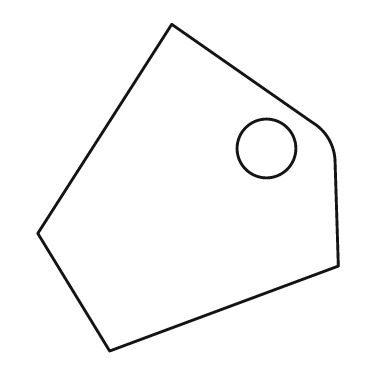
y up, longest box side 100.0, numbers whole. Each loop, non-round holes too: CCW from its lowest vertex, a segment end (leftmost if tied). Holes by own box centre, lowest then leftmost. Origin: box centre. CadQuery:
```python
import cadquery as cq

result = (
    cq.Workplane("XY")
    .moveTo(-24.0, -50.0)
    .lineTo(46.0, -24.0)
    .lineTo(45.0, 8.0)
    .threePointArc((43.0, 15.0), (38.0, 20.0))
    .lineTo(-5.0, 50.0)
    .lineTo(-46.0, -14.0)
    .close()
    .moveTo(24.0, 12.0)
    .circle(9.0)
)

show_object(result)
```